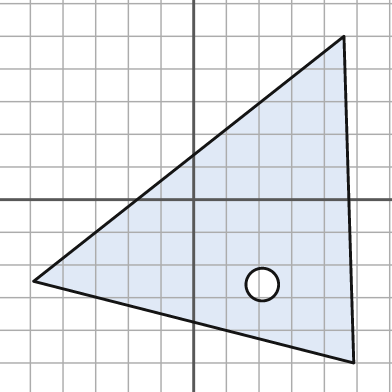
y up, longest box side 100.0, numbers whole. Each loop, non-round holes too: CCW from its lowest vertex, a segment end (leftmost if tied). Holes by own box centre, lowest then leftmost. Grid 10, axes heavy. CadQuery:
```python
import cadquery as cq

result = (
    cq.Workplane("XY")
    .moveTo(49.0, -50.0)
    .lineTo(46.0, 50.0)
    .lineTo(-49.0, -25.0)
    .close()
    .moveTo(21.0, -26.0)
    .circle(5.0)
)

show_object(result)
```